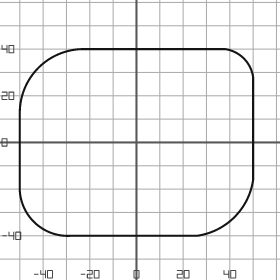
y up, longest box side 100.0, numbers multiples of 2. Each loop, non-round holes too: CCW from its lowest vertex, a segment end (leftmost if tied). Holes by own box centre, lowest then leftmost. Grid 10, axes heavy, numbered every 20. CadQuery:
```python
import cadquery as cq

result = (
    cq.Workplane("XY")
    .moveTo(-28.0, -40.0)
    .lineTo(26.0, -40.0)
    .threePointArc((42.0, -32.0), (50.0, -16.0))
    .lineTo(50.0, 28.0)
    .threePointArc((46.0, 36.0), (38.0, 40.0))
    .lineTo(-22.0, 40.0)
    .threePointArc((-42.0, 32.0), (-50.0, 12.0))
    .lineTo(-50.0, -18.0)
    .threePointArc((-44.0, -34.0), (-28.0, -40.0))
    .close()
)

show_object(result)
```